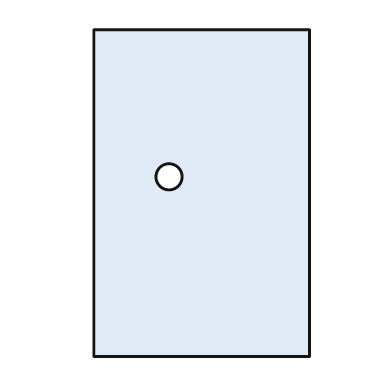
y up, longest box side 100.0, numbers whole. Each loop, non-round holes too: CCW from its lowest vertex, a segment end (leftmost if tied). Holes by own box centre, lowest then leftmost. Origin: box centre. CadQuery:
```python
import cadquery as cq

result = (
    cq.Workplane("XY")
    .moveTo(-33.0, -50.0)
    .lineTo(33.0, -50.0)
    .lineTo(33.0, 50.0)
    .lineTo(-33.0, 50.0)
    .close()
    .moveTo(-10.0, 5.0)
    .circle(4.0)
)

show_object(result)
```